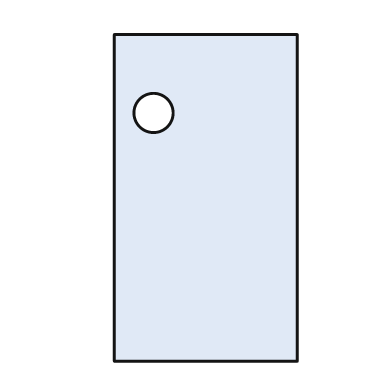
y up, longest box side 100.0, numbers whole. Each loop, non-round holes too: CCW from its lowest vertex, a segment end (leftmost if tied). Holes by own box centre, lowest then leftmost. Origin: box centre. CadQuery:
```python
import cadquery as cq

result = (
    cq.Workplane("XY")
    .moveTo(-28.0, -50.0)
    .lineTo(28.0, -50.0)
    .lineTo(28.0, 50.0)
    .lineTo(-28.0, 50.0)
    .close()
    .moveTo(-16.0, 26.0)
    .circle(6.0)
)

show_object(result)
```